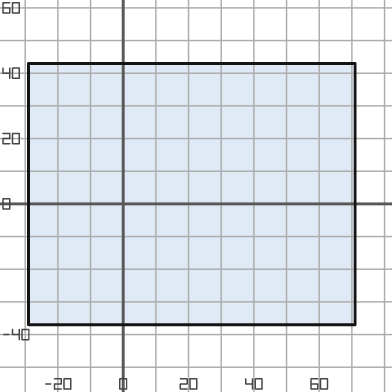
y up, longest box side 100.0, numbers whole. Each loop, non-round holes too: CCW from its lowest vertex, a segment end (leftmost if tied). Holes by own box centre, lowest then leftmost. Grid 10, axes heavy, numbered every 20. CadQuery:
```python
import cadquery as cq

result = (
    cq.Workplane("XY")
    .moveTo(-29.0, -37.0)
    .lineTo(71.0, -37.0)
    .lineTo(71.0, 43.0)
    .lineTo(-29.0, 43.0)
    .close()
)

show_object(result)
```